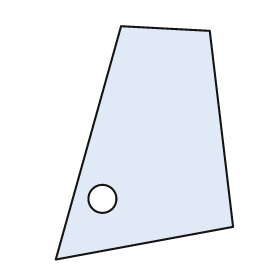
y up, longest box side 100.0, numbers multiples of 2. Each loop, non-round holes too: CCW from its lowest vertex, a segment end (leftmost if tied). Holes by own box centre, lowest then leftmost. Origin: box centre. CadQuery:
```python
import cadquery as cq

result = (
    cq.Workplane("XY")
    .moveTo(-38.0, -50.0)
    .lineTo(38.0, -36.0)
    .lineTo(28.0, 48.0)
    .lineTo(-10.0, 50.0)
    .close()
    .moveTo(-18.0, -24.0)
    .circle(6.0)
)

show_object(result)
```